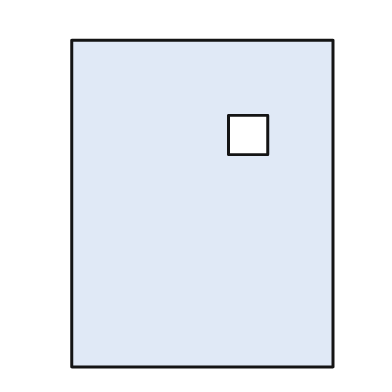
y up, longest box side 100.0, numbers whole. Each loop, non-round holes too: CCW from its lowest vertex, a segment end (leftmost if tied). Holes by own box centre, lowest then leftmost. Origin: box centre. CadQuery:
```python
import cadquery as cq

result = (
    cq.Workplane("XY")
    .moveTo(-40.0, -50.0)
    .lineTo(40.0, -50.0)
    .lineTo(40.0, 50.0)
    .lineTo(-40.0, 50.0)
    .close()
    .moveTo(8.0, 15.0)
    .lineTo(20.0, 15.0)
    .lineTo(20.0, 27.0)
    .lineTo(8.0, 27.0)
    .close()
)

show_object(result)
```